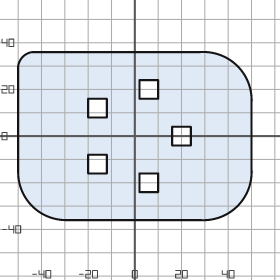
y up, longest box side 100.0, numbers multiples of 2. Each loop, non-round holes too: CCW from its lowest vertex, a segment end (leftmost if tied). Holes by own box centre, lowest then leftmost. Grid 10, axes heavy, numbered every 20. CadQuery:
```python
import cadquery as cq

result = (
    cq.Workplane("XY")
    .moveTo(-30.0, -36.0)
    .lineTo(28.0, -36.0)
    .threePointArc((44.0, -30.0), (50.0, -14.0))
    .lineTo(50.0, 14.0)
    .threePointArc((44.0, 30.0), (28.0, 36.0))
    .lineTo(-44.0, 36.0)
    .threePointArc((-48.0, 34.0), (-50.0, 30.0))
    .lineTo(-50.0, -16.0)
    .threePointArc((-44.0, -30.0), (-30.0, -36.0))
    .close()
    .moveTo(2.0, -24.0)
    .lineTo(10.0, -24.0)
    .lineTo(10.0, -16.0)
    .lineTo(2.0, -16.0)
    .close()
    .moveTo(-20.0, -16.0)
    .lineTo(-12.0, -16.0)
    .lineTo(-12.0, -8.0)
    .lineTo(-20.0, -8.0)
    .close()
    .moveTo(16.0, -4.0)
    .lineTo(24.0, -4.0)
    .lineTo(24.0, 4.0)
    .lineTo(16.0, 4.0)
    .close()
    .moveTo(-20.0, 8.0)
    .lineTo(-12.0, 8.0)
    .lineTo(-12.0, 16.0)
    .lineTo(-20.0, 16.0)
    .close()
    .moveTo(2.0, 16.0)
    .lineTo(10.0, 16.0)
    .lineTo(10.0, 24.0)
    .lineTo(2.0, 24.0)
    .close()
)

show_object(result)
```